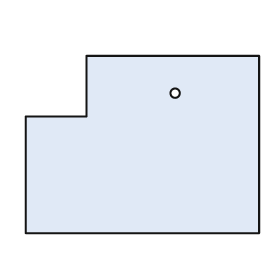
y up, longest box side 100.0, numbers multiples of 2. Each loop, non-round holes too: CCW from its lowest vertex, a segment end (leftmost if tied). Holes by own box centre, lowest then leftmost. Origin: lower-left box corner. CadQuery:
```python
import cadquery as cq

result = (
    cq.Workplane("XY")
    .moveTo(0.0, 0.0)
    .lineTo(100.0, 0.0)
    .lineTo(100.0, 76.0)
    .lineTo(26.0, 76.0)
    .lineTo(26.0, 50.0)
    .lineTo(0.0, 50.0)
    .close()
    .moveTo(64.0, 60.0)
    .circle(2.0)
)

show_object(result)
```